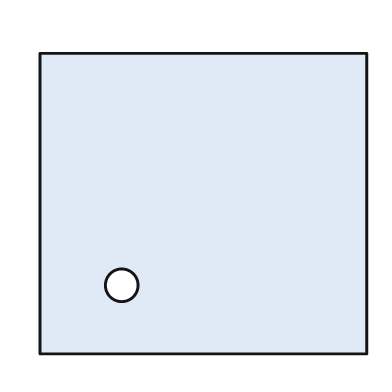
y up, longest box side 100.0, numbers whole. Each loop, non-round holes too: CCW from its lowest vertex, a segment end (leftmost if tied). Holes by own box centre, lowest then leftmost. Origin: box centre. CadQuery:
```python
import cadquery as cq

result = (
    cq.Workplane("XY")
    .moveTo(-50.0, -46.0)
    .lineTo(50.0, -46.0)
    .lineTo(50.0, 46.0)
    .lineTo(-50.0, 46.0)
    .close()
    .moveTo(-25.0, -25.0)
    .circle(5.0)
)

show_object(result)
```